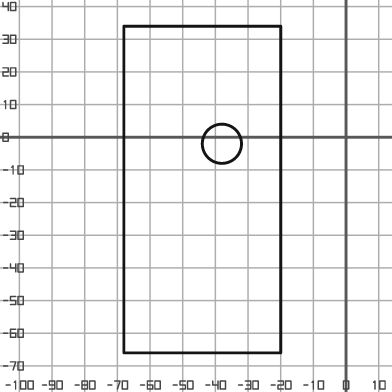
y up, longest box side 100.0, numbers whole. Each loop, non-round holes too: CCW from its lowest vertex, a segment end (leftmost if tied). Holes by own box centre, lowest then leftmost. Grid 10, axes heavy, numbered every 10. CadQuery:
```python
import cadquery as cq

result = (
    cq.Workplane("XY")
    .moveTo(-68.0, -66.0)
    .lineTo(-20.0, -66.0)
    .lineTo(-20.0, 34.0)
    .lineTo(-68.0, 34.0)
    .close()
    .moveTo(-38.0, -2.0)
    .circle(6.0)
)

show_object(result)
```